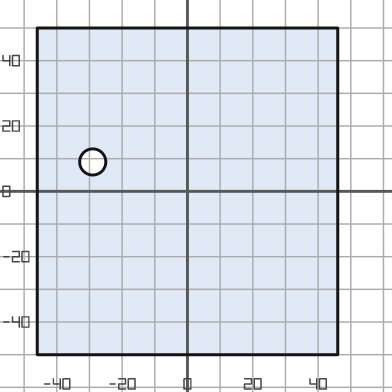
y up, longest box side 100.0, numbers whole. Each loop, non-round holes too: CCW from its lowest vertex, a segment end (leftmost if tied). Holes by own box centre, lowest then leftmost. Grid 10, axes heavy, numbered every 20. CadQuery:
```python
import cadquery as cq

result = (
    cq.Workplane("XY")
    .moveTo(-46.0, -50.0)
    .lineTo(46.0, -50.0)
    .lineTo(46.0, 50.0)
    .lineTo(-46.0, 50.0)
    .close()
    .moveTo(-29.0, 9.0)
    .circle(4.0)
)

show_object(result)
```